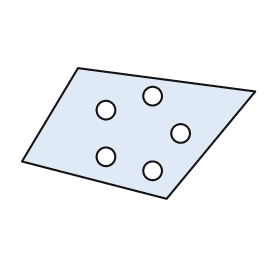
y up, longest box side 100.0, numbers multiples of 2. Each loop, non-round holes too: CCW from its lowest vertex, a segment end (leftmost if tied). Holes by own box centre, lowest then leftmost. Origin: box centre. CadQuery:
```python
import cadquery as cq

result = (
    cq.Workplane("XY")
    .moveTo(12.0, -28.0)
    .lineTo(50.0, 18.0)
    .lineTo(-26.0, 28.0)
    .lineTo(-50.0, -12.0)
    .close()
    .moveTo(6.0, -16.0)
    .circle(4.0)
    .moveTo(-14.0, -10.0)
    .circle(4.0)
    .moveTo(18.0, 0.0)
    .circle(4.0)
    .moveTo(-14.0, 10.0)
    .circle(4.0)
    .moveTo(6.0, 16.0)
    .circle(4.0)
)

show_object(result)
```